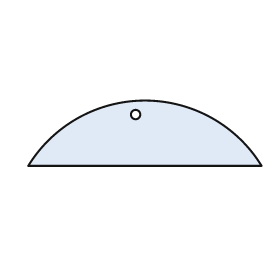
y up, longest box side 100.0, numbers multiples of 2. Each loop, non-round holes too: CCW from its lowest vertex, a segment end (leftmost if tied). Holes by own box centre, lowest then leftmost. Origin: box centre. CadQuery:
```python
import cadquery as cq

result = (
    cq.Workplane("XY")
    .moveTo(-50.0, -14.0)
    .lineTo(50.0, -14.0)
    .threePointArc((0.0, 14.0), (-50.0, -14.0))
    .close()
    .moveTo(-4.0, 8.0)
    .circle(2.0)
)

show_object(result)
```